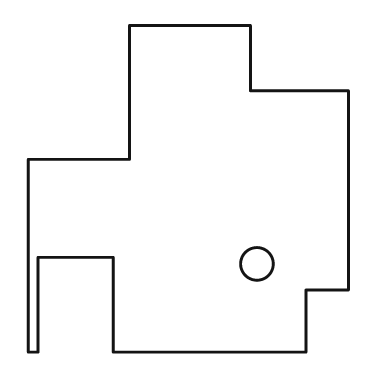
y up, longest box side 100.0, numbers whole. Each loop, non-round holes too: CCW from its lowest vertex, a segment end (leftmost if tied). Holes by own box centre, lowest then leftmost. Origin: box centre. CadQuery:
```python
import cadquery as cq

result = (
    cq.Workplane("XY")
    .moveTo(-49.0, -50.0)
    .lineTo(-46.0, -50.0)
    .lineTo(-46.0, -21.0)
    .lineTo(-23.0, -21.0)
    .lineTo(-23.0, -50.0)
    .lineTo(36.0, -50.0)
    .lineTo(36.0, -31.0)
    .lineTo(49.0, -31.0)
    .lineTo(49.0, 30.0)
    .lineTo(19.0, 30.0)
    .lineTo(19.0, 50.0)
    .lineTo(-18.0, 50.0)
    .lineTo(-18.0, 9.0)
    .lineTo(-49.0, 9.0)
    .close()
    .moveTo(21.0, -23.0)
    .circle(5.0)
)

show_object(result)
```